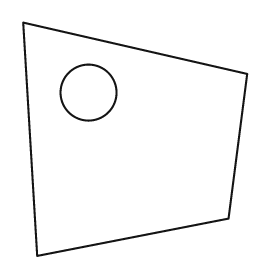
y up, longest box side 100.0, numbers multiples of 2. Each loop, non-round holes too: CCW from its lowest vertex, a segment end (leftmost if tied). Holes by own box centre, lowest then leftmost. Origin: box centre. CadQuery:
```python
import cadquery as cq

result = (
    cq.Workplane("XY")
    .moveTo(-42.0, -50.0)
    .lineTo(40.0, -34.0)
    .lineTo(48.0, 28.0)
    .lineTo(-48.0, 50.0)
    .close()
    .moveTo(-20.0, 20.0)
    .circle(12.0)
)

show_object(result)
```